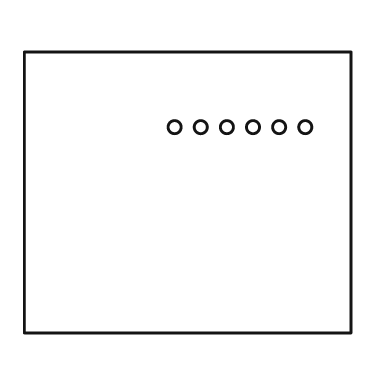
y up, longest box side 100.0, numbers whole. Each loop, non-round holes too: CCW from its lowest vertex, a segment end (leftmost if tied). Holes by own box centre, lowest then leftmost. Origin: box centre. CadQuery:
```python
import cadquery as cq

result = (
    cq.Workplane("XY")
    .moveTo(-50.0, -43.0)
    .lineTo(50.0, -43.0)
    .lineTo(50.0, 43.0)
    .lineTo(-50.0, 43.0)
    .close()
    .moveTo(-4.0, 20.0)
    .circle(2.0)
    .moveTo(4.0, 20.0)
    .circle(2.0)
    .moveTo(12.0, 20.0)
    .circle(2.0)
    .moveTo(20.0, 20.0)
    .circle(2.0)
    .moveTo(28.0, 20.0)
    .circle(2.0)
    .moveTo(36.0, 20.0)
    .circle(2.0)
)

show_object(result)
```